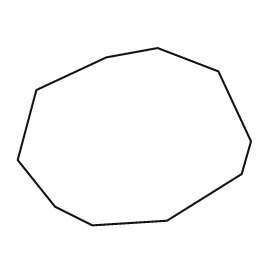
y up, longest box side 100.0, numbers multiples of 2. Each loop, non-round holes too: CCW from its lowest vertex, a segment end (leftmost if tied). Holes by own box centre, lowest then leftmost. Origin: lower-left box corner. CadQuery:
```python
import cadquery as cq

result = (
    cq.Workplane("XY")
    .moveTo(32.0, 0.0)
    .lineTo(64.0, 2.0)
    .lineTo(96.0, 22.0)
    .lineTo(100.0, 36.0)
    .lineTo(86.0, 66.0)
    .lineTo(60.0, 76.0)
    .lineTo(38.0, 72.0)
    .lineTo(8.0, 58.0)
    .lineTo(0.0, 28.0)
    .lineTo(16.0, 8.0)
    .close()
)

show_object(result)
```